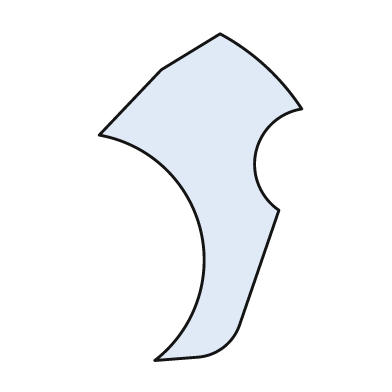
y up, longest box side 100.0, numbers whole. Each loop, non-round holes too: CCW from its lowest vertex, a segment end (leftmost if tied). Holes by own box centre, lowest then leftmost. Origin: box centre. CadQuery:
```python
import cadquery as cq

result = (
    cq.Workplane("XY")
    .moveTo(-14.0, -50.0)
    .lineTo(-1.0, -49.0)
    .threePointArc((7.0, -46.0), (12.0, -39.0))
    .lineTo(24.0, -4.0)
    .threePointArc((17.0, 14.0), (31.0, 27.0))
    .threePointArc((20.0, 40.0), (6.0, 50.0))
    .lineTo(-12.0, 39.0)
    .lineTo(-31.0, 19.0)
    .threePointArc((0.0, -10.0), (-14.0, -50.0))
    .close()
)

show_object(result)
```